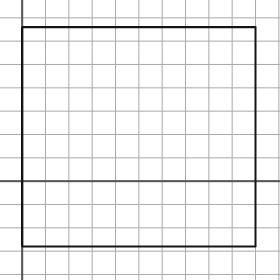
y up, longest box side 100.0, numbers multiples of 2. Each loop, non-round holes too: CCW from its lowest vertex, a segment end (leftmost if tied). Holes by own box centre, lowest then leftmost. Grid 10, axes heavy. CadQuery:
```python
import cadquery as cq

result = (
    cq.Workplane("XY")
    .moveTo(0.0, -28.0)
    .lineTo(100.0, -28.0)
    .lineTo(100.0, 66.0)
    .lineTo(0.0, 66.0)
    .close()
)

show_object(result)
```